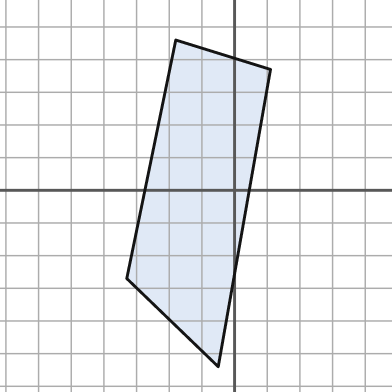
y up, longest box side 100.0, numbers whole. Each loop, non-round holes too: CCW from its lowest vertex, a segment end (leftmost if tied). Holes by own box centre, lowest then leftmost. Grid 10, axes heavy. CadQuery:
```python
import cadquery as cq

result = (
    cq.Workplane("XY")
    .moveTo(-5.0, -54.0)
    .lineTo(11.0, 37.0)
    .lineTo(-18.0, 46.0)
    .lineTo(-33.0, -27.0)
    .close()
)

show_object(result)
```